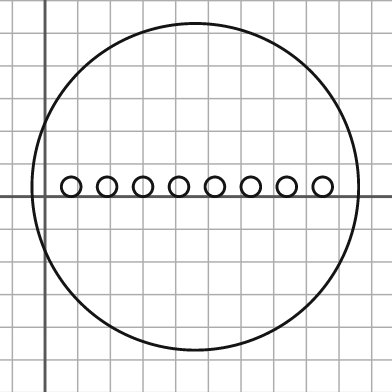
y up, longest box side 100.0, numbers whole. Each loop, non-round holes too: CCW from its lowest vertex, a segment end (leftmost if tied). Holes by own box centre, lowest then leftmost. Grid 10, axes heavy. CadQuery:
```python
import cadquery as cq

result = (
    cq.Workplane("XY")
    .moveTo(46.0, 3.0)
    .circle(50.0)
    .moveTo(8.0, 3.0)
    .circle(3.0)
    .moveTo(19.0, 3.0)
    .circle(3.0)
    .moveTo(30.0, 3.0)
    .circle(3.0)
    .moveTo(41.0, 3.0)
    .circle(3.0)
    .moveTo(52.0, 3.0)
    .circle(3.0)
    .moveTo(63.0, 3.0)
    .circle(3.0)
    .moveTo(74.0, 3.0)
    .circle(3.0)
    .moveTo(85.0, 3.0)
    .circle(3.0)
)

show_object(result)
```